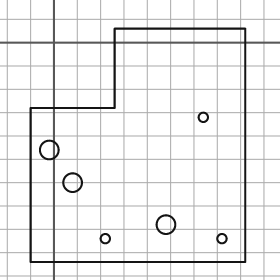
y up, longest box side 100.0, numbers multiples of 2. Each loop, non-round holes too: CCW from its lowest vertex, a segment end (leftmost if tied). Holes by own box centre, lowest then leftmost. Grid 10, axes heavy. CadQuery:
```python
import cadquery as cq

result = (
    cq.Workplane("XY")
    .moveTo(-10.0, -94.0)
    .lineTo(82.0, -94.0)
    .lineTo(82.0, 6.0)
    .lineTo(26.0, 6.0)
    .lineTo(26.0, -28.0)
    .lineTo(-10.0, -28.0)
    .close()
    .moveTo(22.0, -84.0)
    .circle(2.0)
    .moveTo(72.0, -84.0)
    .circle(2.0)
    .moveTo(48.0, -78.0)
    .circle(4.0)
    .moveTo(8.0, -60.0)
    .circle(4.0)
    .moveTo(-2.0, -46.0)
    .circle(4.0)
    .moveTo(64.0, -32.0)
    .circle(2.0)
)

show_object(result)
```